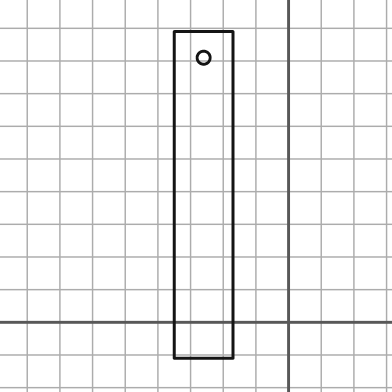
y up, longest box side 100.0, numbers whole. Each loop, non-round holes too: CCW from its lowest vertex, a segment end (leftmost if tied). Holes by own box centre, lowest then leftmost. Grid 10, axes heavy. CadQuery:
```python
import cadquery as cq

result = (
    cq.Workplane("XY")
    .moveTo(-35.0, -11.0)
    .lineTo(-17.0, -11.0)
    .lineTo(-17.0, 89.0)
    .lineTo(-35.0, 89.0)
    .close()
    .moveTo(-26.0, 81.0)
    .circle(2.0)
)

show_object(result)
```